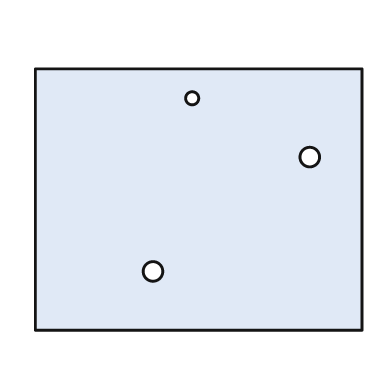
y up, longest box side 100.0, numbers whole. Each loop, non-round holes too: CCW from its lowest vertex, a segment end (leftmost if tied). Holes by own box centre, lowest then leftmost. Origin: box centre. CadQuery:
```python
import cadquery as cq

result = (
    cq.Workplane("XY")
    .moveTo(-50.0, -40.0)
    .lineTo(50.0, -40.0)
    .lineTo(50.0, 40.0)
    .lineTo(-50.0, 40.0)
    .close()
    .moveTo(-14.0, -22.0)
    .circle(3.0)
    .moveTo(34.0, 13.0)
    .circle(3.0)
    .moveTo(-2.0, 31.0)
    .circle(2.0)
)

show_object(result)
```